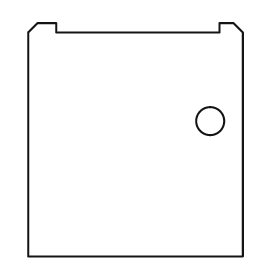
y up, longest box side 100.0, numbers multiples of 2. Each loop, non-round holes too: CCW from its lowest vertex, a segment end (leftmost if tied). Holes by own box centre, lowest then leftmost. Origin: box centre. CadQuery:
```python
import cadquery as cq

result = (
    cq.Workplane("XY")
    .moveTo(-46.0, -50.0)
    .lineTo(46.0, -50.0)
    .lineTo(46.0, 46.0)
    .lineTo(42.0, 50.0)
    .lineTo(36.0, 50.0)
    .lineTo(36.0, 46.0)
    .lineTo(-34.0, 46.0)
    .lineTo(-34.0, 50.0)
    .lineTo(-42.0, 50.0)
    .lineTo(-46.0, 46.0)
    .close()
    .moveTo(32.0, 8.0)
    .circle(6.0)
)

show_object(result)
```